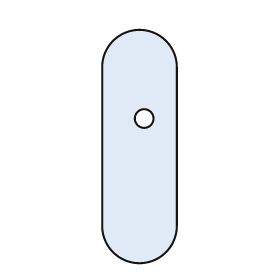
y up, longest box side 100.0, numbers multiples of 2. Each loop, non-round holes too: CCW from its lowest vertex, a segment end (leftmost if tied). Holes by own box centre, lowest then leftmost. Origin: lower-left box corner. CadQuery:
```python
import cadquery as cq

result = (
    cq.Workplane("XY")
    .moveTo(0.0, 16.0)
    .threePointArc((16.0, 0.0), (32.0, 16.0))
    .lineTo(32.0, 84.0)
    .threePointArc((16.0, 100.0), (0.0, 84.0))
    .close()
    .moveTo(18.0, 62.0)
    .circle(4.0)
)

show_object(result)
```